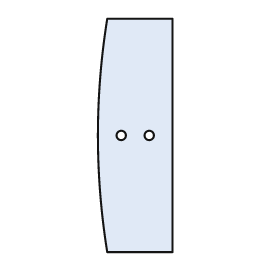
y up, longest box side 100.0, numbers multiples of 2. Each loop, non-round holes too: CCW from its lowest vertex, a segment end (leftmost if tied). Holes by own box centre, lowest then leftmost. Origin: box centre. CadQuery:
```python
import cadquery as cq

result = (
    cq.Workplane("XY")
    .moveTo(-12.0, -50.0)
    .lineTo(16.0, -50.0)
    .lineTo(16.0, 50.0)
    .lineTo(-12.0, 50.0)
    .threePointArc((-16.0, 0.0), (-12.0, -50.0))
    .close()
    .moveTo(-6.0, 0.0)
    .circle(2.0)
    .moveTo(6.0, 0.0)
    .circle(2.0)
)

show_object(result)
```